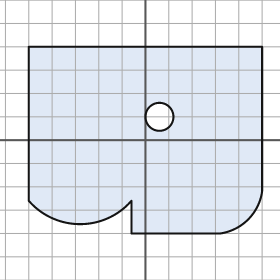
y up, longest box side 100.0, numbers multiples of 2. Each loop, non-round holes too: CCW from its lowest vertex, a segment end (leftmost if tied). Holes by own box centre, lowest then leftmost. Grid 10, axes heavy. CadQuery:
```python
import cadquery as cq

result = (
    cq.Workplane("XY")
    .moveTo(-6.0, -40.0)
    .lineTo(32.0, -40.0)
    .threePointArc((44.0, -34.0), (50.0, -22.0))
    .lineTo(50.0, 40.0)
    .lineTo(-50.0, 40.0)
    .lineTo(-50.0, -26.0)
    .threePointArc((-28.0, -36.0), (-6.0, -26.0))
    .close()
    .moveTo(6.0, 10.0)
    .circle(6.0)
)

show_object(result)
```